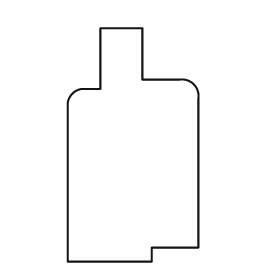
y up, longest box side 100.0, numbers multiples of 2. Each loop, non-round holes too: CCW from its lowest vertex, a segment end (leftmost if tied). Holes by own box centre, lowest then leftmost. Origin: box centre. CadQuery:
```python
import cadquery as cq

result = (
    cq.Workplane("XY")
    .moveTo(-28.0, -50.0)
    .lineTo(8.0, -50.0)
    .lineTo(8.0, -44.0)
    .lineTo(28.0, -44.0)
    .lineTo(28.0, 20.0)
    .threePointArc((26.0, 26.0), (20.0, 28.0))
    .lineTo(4.0, 28.0)
    .lineTo(4.0, 50.0)
    .lineTo(-14.0, 50.0)
    .lineTo(-14.0, 24.0)
    .lineTo(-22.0, 24.0)
    .threePointArc((-26.0, 22.0), (-28.0, 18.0))
    .close()
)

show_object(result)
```